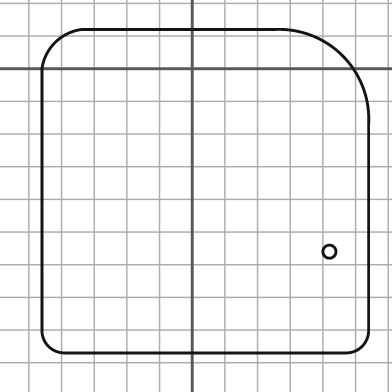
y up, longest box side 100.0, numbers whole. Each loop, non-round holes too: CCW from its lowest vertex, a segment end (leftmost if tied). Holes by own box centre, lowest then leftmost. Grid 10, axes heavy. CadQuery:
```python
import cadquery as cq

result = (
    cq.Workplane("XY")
    .moveTo(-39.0, -87.0)
    .lineTo(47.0, -87.0)
    .threePointArc((52.0, -85.0), (54.0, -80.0))
    .lineTo(54.0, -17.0)
    .threePointArc((46.0, 4.0), (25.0, 12.0))
    .lineTo(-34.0, 12.0)
    .threePointArc((-42.0, 8.0), (-46.0, 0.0))
    .lineTo(-46.0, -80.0)
    .threePointArc((-44.0, -85.0), (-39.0, -87.0))
    .close()
    .moveTo(42.0, -56.0)
    .circle(2.0)
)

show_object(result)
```